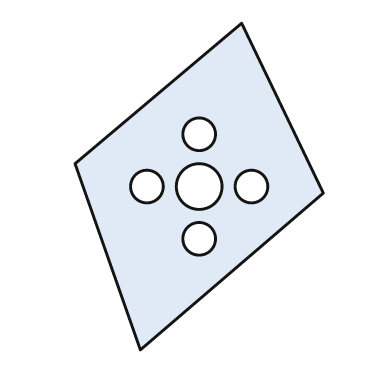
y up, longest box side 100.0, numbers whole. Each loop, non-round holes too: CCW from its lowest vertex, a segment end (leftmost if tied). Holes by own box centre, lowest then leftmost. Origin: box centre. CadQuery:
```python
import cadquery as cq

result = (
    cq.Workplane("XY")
    .moveTo(-18.0, -50.0)
    .lineTo(38.0, -2.0)
    .lineTo(13.0, 50.0)
    .lineTo(-38.0, 7.0)
    .close()
    .moveTo(0.0, -16.0)
    .circle(5.0)
    .moveTo(-16.0, 0.0)
    .circle(5.0)
    .moveTo(0.0, 0.0)
    .circle(7.0)
    .moveTo(16.0, 0.0)
    .circle(5.0)
    .moveTo(0.0, 16.0)
    .circle(5.0)
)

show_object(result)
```